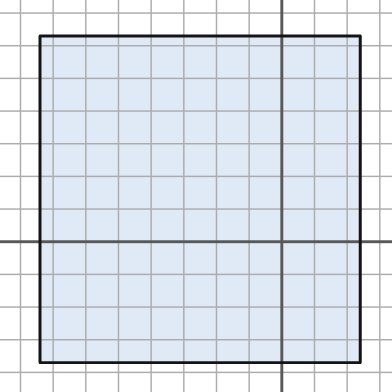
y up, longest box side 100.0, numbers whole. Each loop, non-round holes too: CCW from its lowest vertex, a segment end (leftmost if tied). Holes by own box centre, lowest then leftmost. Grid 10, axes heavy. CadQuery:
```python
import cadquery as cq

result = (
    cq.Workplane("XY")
    .moveTo(-74.0, -37.0)
    .lineTo(24.0, -37.0)
    .lineTo(24.0, 63.0)
    .lineTo(-74.0, 63.0)
    .close()
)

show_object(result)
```